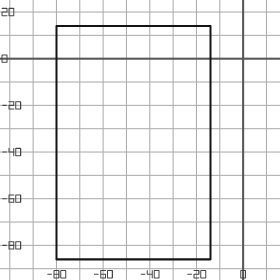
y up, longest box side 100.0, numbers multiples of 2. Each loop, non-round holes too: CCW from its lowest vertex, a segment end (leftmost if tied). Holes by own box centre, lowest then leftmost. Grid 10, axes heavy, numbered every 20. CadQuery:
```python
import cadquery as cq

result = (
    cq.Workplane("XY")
    .moveTo(-80.0, -86.0)
    .lineTo(-14.0, -86.0)
    .lineTo(-14.0, 14.0)
    .lineTo(-80.0, 14.0)
    .close()
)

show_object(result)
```